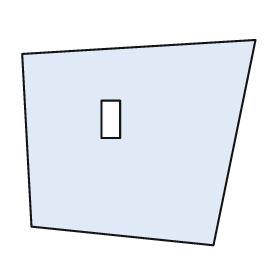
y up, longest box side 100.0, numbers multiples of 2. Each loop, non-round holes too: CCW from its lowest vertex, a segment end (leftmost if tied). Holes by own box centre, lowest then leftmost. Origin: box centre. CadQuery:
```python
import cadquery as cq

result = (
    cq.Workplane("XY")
    .moveTo(32.0, -44.0)
    .lineTo(50.0, 44.0)
    .lineTo(-50.0, 38.0)
    .lineTo(-46.0, -36.0)
    .close()
    .moveTo(-16.0, 2.0)
    .lineTo(-8.0, 2.0)
    .lineTo(-8.0, 18.0)
    .lineTo(-16.0, 18.0)
    .close()
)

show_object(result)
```